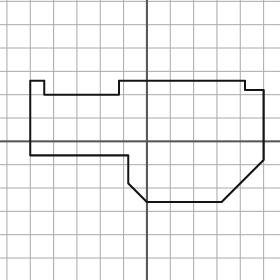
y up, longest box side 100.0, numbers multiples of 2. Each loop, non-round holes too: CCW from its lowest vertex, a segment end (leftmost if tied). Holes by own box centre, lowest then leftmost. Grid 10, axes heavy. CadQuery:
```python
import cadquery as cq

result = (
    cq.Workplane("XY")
    .moveTo(0.0, -26.0)
    .lineTo(32.0, -26.0)
    .lineTo(50.0, -8.0)
    .lineTo(50.0, 22.0)
    .lineTo(42.0, 22.0)
    .lineTo(42.0, 26.0)
    .lineTo(-12.0, 26.0)
    .lineTo(-12.0, 20.0)
    .lineTo(-44.0, 20.0)
    .lineTo(-44.0, 26.0)
    .lineTo(-50.0, 26.0)
    .lineTo(-50.0, -6.0)
    .lineTo(-8.0, -6.0)
    .lineTo(-8.0, -18.0)
    .close()
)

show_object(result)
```